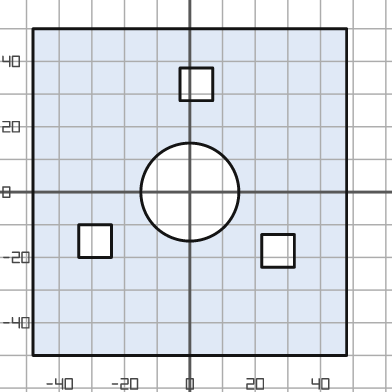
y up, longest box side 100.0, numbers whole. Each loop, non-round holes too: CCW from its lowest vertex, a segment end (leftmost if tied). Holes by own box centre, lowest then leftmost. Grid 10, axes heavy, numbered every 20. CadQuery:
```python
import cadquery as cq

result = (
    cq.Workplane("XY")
    .moveTo(-48.0, -50.0)
    .lineTo(48.0, -50.0)
    .lineTo(48.0, 50.0)
    .lineTo(-48.0, 50.0)
    .close()
    .moveTo(22.0, -23.0)
    .lineTo(32.0, -23.0)
    .lineTo(32.0, -13.0)
    .lineTo(22.0, -13.0)
    .close()
    .moveTo(-34.0, -20.0)
    .lineTo(-24.0, -20.0)
    .lineTo(-24.0, -10.0)
    .lineTo(-34.0, -10.0)
    .close()
    .moveTo(0.0, 0.0)
    .circle(15.0)
    .moveTo(-3.0, 28.0)
    .lineTo(7.0, 28.0)
    .lineTo(7.0, 38.0)
    .lineTo(-3.0, 38.0)
    .close()
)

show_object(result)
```